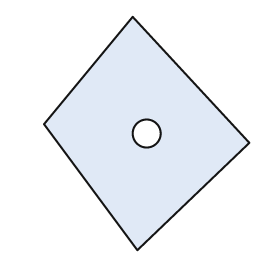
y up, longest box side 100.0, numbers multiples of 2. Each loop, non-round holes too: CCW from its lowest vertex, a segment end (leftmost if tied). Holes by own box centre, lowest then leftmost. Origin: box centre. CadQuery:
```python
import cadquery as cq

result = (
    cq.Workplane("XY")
    .moveTo(-4.0, -50.0)
    .lineTo(44.0, -4.0)
    .lineTo(-6.0, 50.0)
    .lineTo(-44.0, 4.0)
    .close()
    .moveTo(0.0, 0.0)
    .circle(6.0)
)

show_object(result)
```